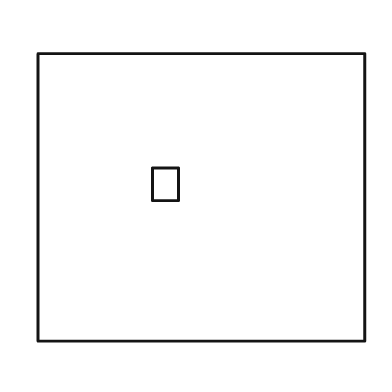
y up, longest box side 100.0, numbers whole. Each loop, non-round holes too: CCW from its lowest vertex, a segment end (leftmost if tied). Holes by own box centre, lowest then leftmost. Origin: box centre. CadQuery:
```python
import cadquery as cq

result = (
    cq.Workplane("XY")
    .moveTo(-50.0, -44.0)
    .lineTo(50.0, -44.0)
    .lineTo(50.0, 44.0)
    .lineTo(-50.0, 44.0)
    .close()
    .moveTo(-15.0, -1.0)
    .lineTo(-7.0, -1.0)
    .lineTo(-7.0, 9.0)
    .lineTo(-15.0, 9.0)
    .close()
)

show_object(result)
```